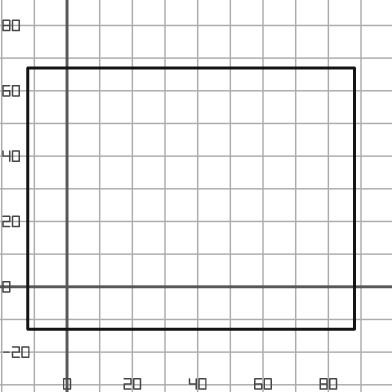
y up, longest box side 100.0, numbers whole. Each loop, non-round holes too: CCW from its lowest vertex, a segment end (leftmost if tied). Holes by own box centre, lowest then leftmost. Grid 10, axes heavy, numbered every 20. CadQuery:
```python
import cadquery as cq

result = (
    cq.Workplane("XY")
    .moveTo(-12.0, -13.0)
    .lineTo(88.0, -13.0)
    .lineTo(88.0, 67.0)
    .lineTo(-12.0, 67.0)
    .close()
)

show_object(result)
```